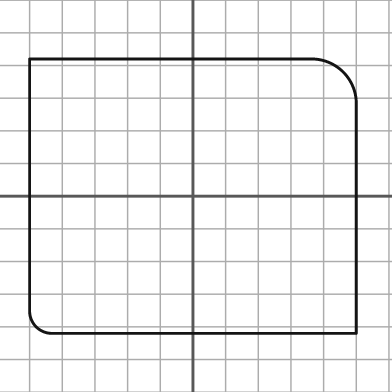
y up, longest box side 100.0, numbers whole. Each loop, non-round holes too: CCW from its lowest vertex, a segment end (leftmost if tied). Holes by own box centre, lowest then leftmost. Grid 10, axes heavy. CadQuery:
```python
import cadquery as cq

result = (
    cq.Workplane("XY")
    .moveTo(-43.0, -42.0)
    .lineTo(50.0, -42.0)
    .lineTo(50.0, 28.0)
    .threePointArc((46.0, 38.0), (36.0, 42.0))
    .lineTo(-50.0, 42.0)
    .lineTo(-50.0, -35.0)
    .threePointArc((-48.0, -40.0), (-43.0, -42.0))
    .close()
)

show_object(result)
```